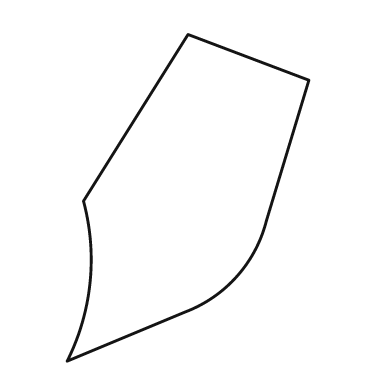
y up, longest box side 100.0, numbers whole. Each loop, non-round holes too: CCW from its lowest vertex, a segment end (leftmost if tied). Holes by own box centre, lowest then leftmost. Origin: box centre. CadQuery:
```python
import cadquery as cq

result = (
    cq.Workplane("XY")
    .moveTo(-37.0, -50.0)
    .lineTo(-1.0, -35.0)
    .threePointArc((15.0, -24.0), (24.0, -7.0))
    .lineTo(37.0, 36.0)
    .lineTo(0.0, 50.0)
    .lineTo(-32.0, -1.0)
    .threePointArc((-30.0, -26.0), (-37.0, -50.0))
    .close()
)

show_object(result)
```